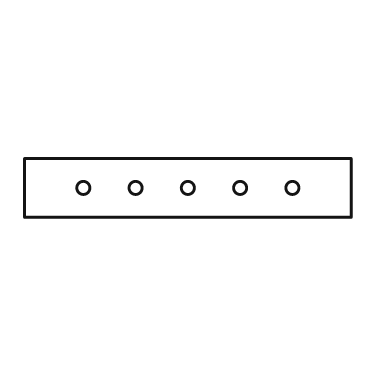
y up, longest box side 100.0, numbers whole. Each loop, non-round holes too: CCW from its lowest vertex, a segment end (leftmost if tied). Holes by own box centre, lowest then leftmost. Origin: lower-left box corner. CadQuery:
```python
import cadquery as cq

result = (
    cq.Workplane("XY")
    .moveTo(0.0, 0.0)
    .lineTo(100.0, 0.0)
    .lineTo(100.0, 18.0)
    .lineTo(0.0, 18.0)
    .close()
    .moveTo(18.0, 9.0)
    .circle(2.0)
    .moveTo(34.0, 9.0)
    .circle(2.0)
    .moveTo(50.0, 9.0)
    .circle(2.0)
    .moveTo(66.0, 9.0)
    .circle(2.0)
    .moveTo(82.0, 9.0)
    .circle(2.0)
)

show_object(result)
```